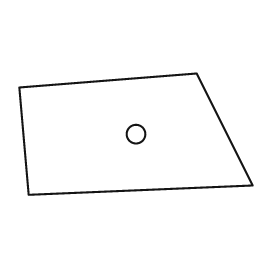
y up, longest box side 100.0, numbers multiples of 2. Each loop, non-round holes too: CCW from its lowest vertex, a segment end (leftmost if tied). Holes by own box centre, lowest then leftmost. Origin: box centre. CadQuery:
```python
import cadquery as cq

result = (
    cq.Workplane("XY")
    .moveTo(-46.0, -26.0)
    .lineTo(50.0, -22.0)
    .lineTo(26.0, 26.0)
    .lineTo(-50.0, 20.0)
    .close()
    .moveTo(0.0, 0.0)
    .circle(4.0)
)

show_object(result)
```